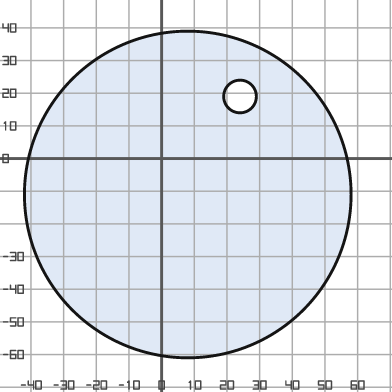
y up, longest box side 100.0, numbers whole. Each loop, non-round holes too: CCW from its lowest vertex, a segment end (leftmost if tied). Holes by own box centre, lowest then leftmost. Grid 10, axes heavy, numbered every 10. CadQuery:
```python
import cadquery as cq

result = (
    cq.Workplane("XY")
    .moveTo(8.0, -11.0)
    .circle(50.0)
    .moveTo(24.0, 19.0)
    .circle(5.0)
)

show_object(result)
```